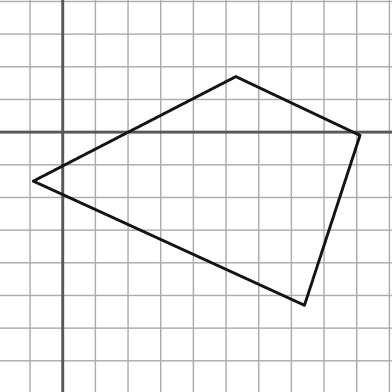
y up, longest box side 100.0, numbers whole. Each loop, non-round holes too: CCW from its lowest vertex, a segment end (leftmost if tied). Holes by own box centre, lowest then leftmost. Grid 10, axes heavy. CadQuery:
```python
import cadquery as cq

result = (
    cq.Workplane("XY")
    .moveTo(74.0, -53.0)
    .lineTo(91.0, -1.0)
    .lineTo(53.0, 17.0)
    .lineTo(-9.0, -15.0)
    .close()
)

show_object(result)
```